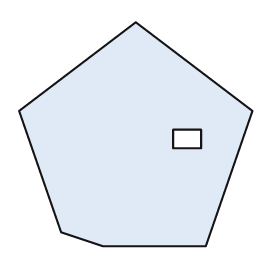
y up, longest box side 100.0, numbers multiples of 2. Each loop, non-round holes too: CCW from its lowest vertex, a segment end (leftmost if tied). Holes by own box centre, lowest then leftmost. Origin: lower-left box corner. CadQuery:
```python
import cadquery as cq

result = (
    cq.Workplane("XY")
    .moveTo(36.0, 0.0)
    .lineTo(80.0, 0.0)
    .lineTo(100.0, 58.0)
    .lineTo(50.0, 96.0)
    .lineTo(0.0, 58.0)
    .lineTo(18.0, 6.0)
    .close()
    .moveTo(66.0, 42.0)
    .lineTo(78.0, 42.0)
    .lineTo(78.0, 50.0)
    .lineTo(66.0, 50.0)
    .close()
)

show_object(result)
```